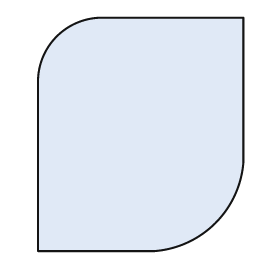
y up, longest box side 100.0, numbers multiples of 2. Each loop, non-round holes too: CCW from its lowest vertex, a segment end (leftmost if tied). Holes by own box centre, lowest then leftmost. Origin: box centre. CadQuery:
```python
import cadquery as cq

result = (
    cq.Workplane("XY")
    .moveTo(-44.0, -50.0)
    .lineTo(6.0, -50.0)
    .threePointArc((32.0, -38.0), (44.0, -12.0))
    .lineTo(44.0, 50.0)
    .lineTo(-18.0, 50.0)
    .threePointArc((-36.0, 42.0), (-44.0, 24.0))
    .close()
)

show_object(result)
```